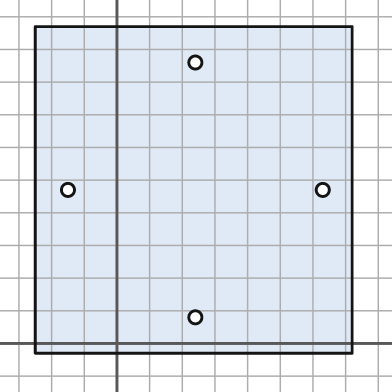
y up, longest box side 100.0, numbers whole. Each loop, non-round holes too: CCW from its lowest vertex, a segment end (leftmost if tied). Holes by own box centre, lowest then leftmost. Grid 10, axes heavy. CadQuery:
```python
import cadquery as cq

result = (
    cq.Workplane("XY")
    .moveTo(-25.0, -3.0)
    .lineTo(72.0, -3.0)
    .lineTo(72.0, 97.0)
    .lineTo(-25.0, 97.0)
    .close()
    .moveTo(24.0, 8.0)
    .circle(2.0)
    .moveTo(-15.0, 47.0)
    .circle(2.0)
    .moveTo(63.0, 47.0)
    .circle(2.0)
    .moveTo(24.0, 86.0)
    .circle(2.0)
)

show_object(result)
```